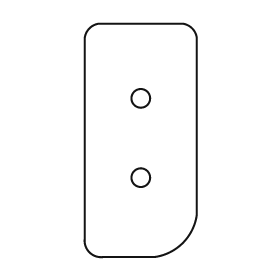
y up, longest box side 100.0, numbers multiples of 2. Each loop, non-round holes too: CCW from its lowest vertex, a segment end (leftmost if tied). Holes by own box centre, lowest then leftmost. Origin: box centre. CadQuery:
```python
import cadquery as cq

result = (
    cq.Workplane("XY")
    .moveTo(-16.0, -50.0)
    .lineTo(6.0, -50.0)
    .threePointArc((18.0, -44.0), (24.0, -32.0))
    .lineTo(24.0, 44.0)
    .threePointArc((22.0, 48.0), (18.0, 50.0))
    .lineTo(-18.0, 50.0)
    .threePointArc((-22.0, 48.0), (-24.0, 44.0))
    .lineTo(-24.0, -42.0)
    .threePointArc((-22.0, -48.0), (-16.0, -50.0))
    .close()
    .moveTo(0.0, -16.0)
    .circle(4.0)
    .moveTo(0.0, 18.0)
    .circle(4.0)
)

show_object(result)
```